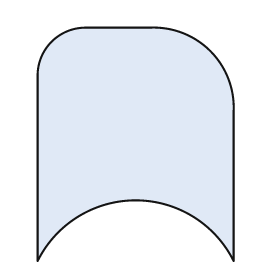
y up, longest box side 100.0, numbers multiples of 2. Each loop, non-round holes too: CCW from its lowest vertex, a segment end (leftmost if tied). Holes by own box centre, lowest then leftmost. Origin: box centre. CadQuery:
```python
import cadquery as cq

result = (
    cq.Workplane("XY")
    .moveTo(-42.0, -50.0)
    .threePointArc((0.0, -24.0), (42.0, -50.0))
    .lineTo(42.0, 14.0)
    .threePointArc((32.0, 40.0), (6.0, 50.0))
    .lineTo(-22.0, 50.0)
    .threePointArc((-36.0, 44.0), (-42.0, 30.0))
    .close()
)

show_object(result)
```